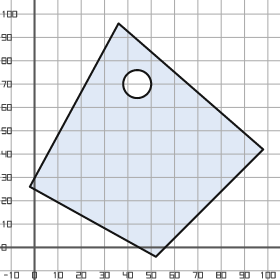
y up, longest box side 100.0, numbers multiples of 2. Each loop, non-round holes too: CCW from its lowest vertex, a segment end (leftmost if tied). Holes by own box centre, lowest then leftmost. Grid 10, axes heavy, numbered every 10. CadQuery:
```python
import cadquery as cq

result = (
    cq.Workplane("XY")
    .moveTo(52.0, -4.0)
    .lineTo(98.0, 42.0)
    .lineTo(36.0, 96.0)
    .lineTo(-2.0, 26.0)
    .close()
    .moveTo(44.0, 70.0)
    .circle(6.0)
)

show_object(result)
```